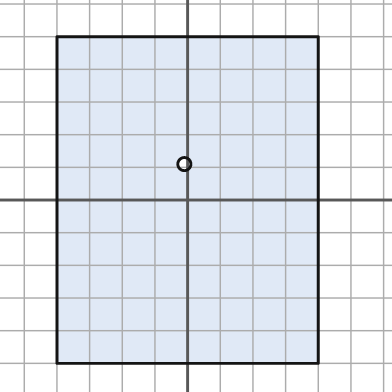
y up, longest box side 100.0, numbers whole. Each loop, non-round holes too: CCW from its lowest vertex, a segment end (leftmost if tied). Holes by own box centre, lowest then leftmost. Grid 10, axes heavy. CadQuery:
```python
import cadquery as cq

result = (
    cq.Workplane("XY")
    .moveTo(-40.0, -50.0)
    .lineTo(40.0, -50.0)
    .lineTo(40.0, 50.0)
    .lineTo(-40.0, 50.0)
    .close()
    .moveTo(-1.0, 11.0)
    .circle(2.0)
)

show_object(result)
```